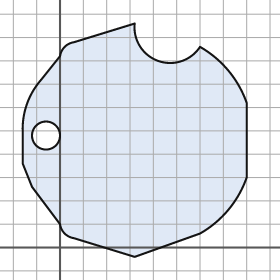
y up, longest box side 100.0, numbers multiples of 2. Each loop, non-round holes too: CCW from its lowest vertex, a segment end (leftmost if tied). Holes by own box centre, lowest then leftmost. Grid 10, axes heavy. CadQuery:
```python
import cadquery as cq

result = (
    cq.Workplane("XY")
    .moveTo(32.0, -4.0)
    .lineTo(60.0, 6.0)
    .threePointArc((72.0, 16.0), (80.0, 30.0))
    .lineTo(80.0, 62.0)
    .threePointArc((72.0, 76.0), (60.0, 86.0))
    .threePointArc((42.0, 80.0), (32.0, 96.0))
    .lineTo(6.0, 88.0)
    .threePointArc((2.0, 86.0), (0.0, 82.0))
    .lineTo(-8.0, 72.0)
    .threePointArc((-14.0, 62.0), (-16.0, 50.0))
    .lineTo(-16.0, 36.0)
    .lineTo(-12.0, 26.0)
    .lineTo(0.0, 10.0)
    .threePointArc((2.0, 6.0), (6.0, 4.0))
    .close()
    .moveTo(-6.0, 48.0)
    .circle(6.0)
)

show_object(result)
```